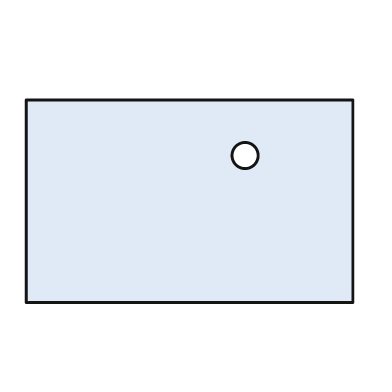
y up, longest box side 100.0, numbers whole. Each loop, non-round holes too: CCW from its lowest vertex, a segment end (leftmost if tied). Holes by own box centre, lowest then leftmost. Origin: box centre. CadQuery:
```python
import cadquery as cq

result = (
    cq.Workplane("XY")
    .moveTo(-50.0, -31.0)
    .lineTo(50.0, -31.0)
    .lineTo(50.0, 31.0)
    .lineTo(-50.0, 31.0)
    .close()
    .moveTo(17.0, 14.0)
    .circle(4.0)
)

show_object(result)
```